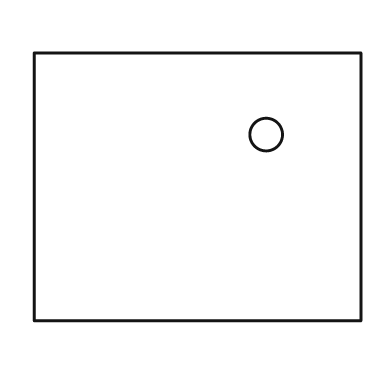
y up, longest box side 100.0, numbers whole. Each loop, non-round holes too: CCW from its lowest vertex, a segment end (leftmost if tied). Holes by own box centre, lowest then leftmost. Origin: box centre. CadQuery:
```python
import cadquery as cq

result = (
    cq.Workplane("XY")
    .moveTo(-50.0, -41.0)
    .lineTo(50.0, -41.0)
    .lineTo(50.0, 41.0)
    .lineTo(-50.0, 41.0)
    .close()
    .moveTo(21.0, 16.0)
    .circle(5.0)
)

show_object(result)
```